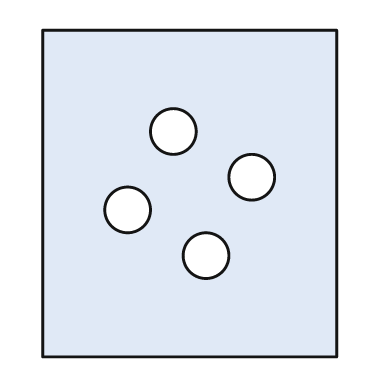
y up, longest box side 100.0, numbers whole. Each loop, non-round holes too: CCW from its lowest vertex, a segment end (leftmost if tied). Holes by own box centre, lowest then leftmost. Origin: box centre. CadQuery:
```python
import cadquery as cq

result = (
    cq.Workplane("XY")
    .moveTo(-45.0, -50.0)
    .lineTo(45.0, -50.0)
    .lineTo(45.0, 50.0)
    .lineTo(-45.0, 50.0)
    .close()
    .moveTo(5.0, -19.0)
    .circle(7.0)
    .moveTo(-19.0, -5.0)
    .circle(7.0)
    .moveTo(19.0, 5.0)
    .circle(7.0)
    .moveTo(-5.0, 19.0)
    .circle(7.0)
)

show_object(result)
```